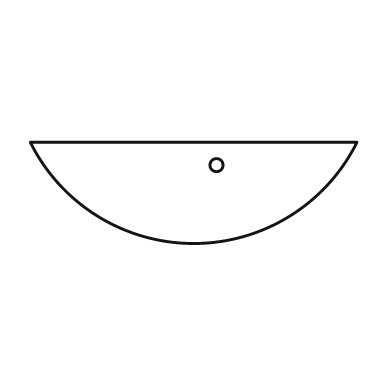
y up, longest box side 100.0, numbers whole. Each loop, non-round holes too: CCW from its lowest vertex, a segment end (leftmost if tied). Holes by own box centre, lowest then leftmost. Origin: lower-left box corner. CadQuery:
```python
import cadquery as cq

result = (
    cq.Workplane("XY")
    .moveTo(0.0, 31.0)
    .threePointArc((50.0, 0.0), (100.0, 31.0))
    .close()
    .moveTo(57.0, 24.0)
    .circle(2.0)
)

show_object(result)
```